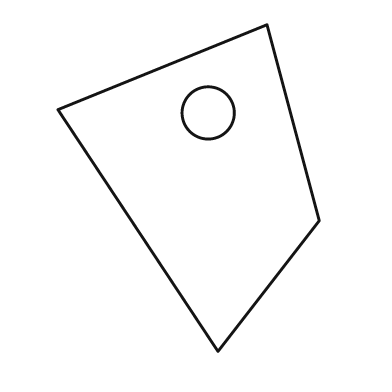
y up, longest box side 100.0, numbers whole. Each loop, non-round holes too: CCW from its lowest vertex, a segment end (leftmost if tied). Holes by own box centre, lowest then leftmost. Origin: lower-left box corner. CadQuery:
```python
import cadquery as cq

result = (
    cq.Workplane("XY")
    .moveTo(49.0, 0.0)
    .lineTo(80.0, 40.0)
    .lineTo(64.0, 100.0)
    .lineTo(0.0, 74.0)
    .close()
    .moveTo(46.0, 73.0)
    .circle(8.0)
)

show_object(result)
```